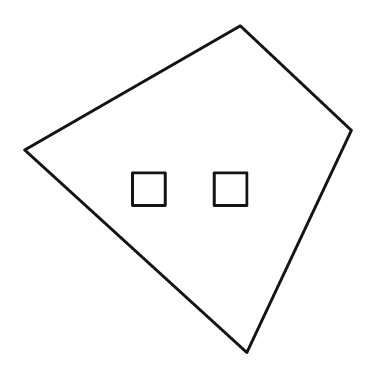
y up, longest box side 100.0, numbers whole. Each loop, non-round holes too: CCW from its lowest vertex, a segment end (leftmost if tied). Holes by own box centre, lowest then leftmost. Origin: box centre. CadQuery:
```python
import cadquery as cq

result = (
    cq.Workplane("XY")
    .moveTo(18.0, -50.0)
    .lineTo(50.0, 18.0)
    .lineTo(16.0, 50.0)
    .lineTo(-50.0, 12.0)
    .close()
    .moveTo(-17.0, -5.0)
    .lineTo(-7.0, -5.0)
    .lineTo(-7.0, 5.0)
    .lineTo(-17.0, 5.0)
    .close()
    .moveTo(8.0, -5.0)
    .lineTo(18.0, -5.0)
    .lineTo(18.0, 5.0)
    .lineTo(8.0, 5.0)
    .close()
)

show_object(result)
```